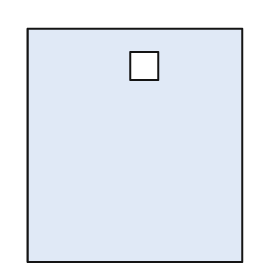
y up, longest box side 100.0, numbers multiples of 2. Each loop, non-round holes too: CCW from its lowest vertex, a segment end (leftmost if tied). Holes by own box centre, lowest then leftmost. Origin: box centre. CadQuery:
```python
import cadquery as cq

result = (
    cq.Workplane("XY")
    .moveTo(-46.0, -50.0)
    .lineTo(46.0, -50.0)
    .lineTo(46.0, 50.0)
    .lineTo(-46.0, 50.0)
    .close()
    .moveTo(-2.0, 28.0)
    .lineTo(10.0, 28.0)
    .lineTo(10.0, 40.0)
    .lineTo(-2.0, 40.0)
    .close()
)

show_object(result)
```